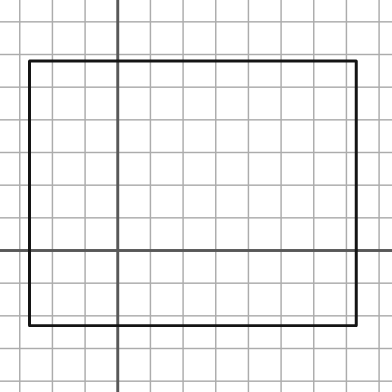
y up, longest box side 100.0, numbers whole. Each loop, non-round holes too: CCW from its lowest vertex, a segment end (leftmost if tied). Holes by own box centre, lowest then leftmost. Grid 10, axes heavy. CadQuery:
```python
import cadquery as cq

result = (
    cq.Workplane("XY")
    .moveTo(-27.0, -23.0)
    .lineTo(73.0, -23.0)
    .lineTo(73.0, 58.0)
    .lineTo(-27.0, 58.0)
    .close()
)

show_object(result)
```